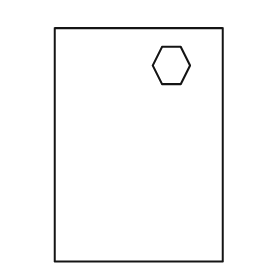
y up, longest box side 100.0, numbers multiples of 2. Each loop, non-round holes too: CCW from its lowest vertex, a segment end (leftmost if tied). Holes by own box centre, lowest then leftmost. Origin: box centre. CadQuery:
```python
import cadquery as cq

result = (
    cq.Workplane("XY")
    .moveTo(-36.0, -50.0)
    .lineTo(36.0, -50.0)
    .lineTo(36.0, 50.0)
    .lineTo(-36.0, 50.0)
    .close()
    .moveTo(10.0, 26.0)
    .lineTo(18.0, 26.0)
    .lineTo(22.0, 34.0)
    .lineTo(18.0, 42.0)
    .lineTo(10.0, 42.0)
    .lineTo(6.0, 34.0)
    .close()
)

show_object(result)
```